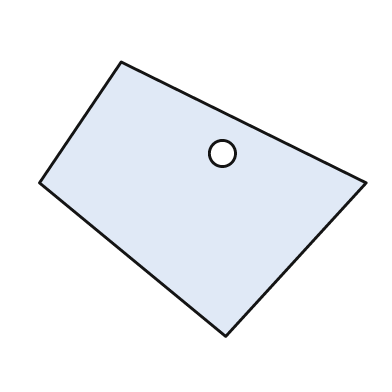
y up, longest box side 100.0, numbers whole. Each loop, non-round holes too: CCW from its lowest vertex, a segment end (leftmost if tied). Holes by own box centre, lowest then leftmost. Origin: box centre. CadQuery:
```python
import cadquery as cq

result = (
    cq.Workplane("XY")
    .moveTo(7.0, -42.0)
    .lineTo(50.0, 5.0)
    .lineTo(-25.0, 42.0)
    .lineTo(-50.0, 5.0)
    .close()
    .moveTo(6.0, 14.0)
    .circle(4.0)
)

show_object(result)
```